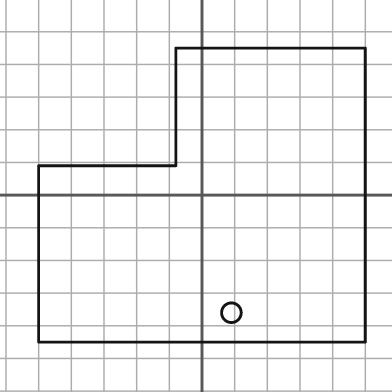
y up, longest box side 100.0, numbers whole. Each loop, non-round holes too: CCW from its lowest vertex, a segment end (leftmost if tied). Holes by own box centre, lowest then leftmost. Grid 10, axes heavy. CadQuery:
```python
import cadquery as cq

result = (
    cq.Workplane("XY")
    .moveTo(-50.0, -45.0)
    .lineTo(50.0, -45.0)
    .lineTo(50.0, 45.0)
    .lineTo(-8.0, 45.0)
    .lineTo(-8.0, 9.0)
    .lineTo(-50.0, 9.0)
    .close()
    .moveTo(9.0, -36.0)
    .circle(3.0)
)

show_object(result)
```